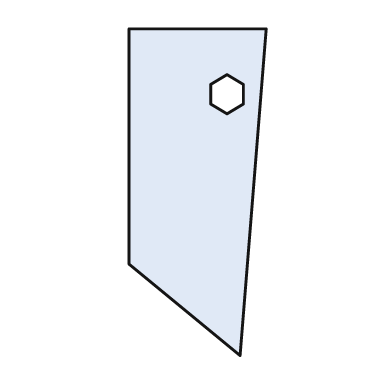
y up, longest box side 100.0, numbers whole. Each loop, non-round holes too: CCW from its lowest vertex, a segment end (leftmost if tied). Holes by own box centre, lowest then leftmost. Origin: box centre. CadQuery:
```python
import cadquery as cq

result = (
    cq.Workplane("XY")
    .moveTo(13.0, -50.0)
    .lineTo(21.0, 50.0)
    .lineTo(-21.0, 50.0)
    .lineTo(-21.0, -22.0)
    .close()
    .moveTo(9.0, 24.0)
    .lineTo(14.0, 27.0)
    .lineTo(14.0, 33.0)
    .lineTo(9.0, 36.0)
    .lineTo(4.0, 33.0)
    .lineTo(4.0, 27.0)
    .close()
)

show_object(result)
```